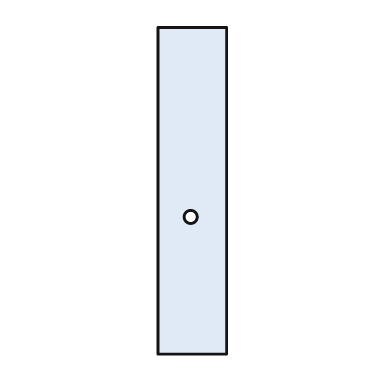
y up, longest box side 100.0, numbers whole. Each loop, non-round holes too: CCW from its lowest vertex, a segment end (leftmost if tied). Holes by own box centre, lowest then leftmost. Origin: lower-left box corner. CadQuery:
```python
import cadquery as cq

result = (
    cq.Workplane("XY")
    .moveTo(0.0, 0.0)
    .lineTo(21.0, 0.0)
    .lineTo(21.0, 100.0)
    .lineTo(0.0, 100.0)
    .close()
    .moveTo(10.0, 42.0)
    .circle(2.0)
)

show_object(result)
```